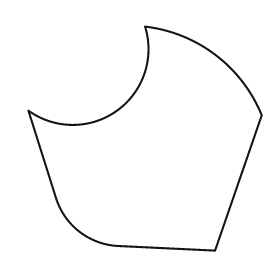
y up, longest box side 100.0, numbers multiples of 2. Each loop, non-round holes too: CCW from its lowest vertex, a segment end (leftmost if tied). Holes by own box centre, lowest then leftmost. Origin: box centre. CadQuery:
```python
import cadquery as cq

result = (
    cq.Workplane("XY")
    .moveTo(30.0, -48.0)
    .lineTo(50.0, 10.0)
    .threePointArc((30.0, 36.0), (0.0, 48.0))
    .threePointArc((-12.0, 12.0), (-50.0, 12.0))
    .lineTo(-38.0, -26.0)
    .threePointArc((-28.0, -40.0), (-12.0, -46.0))
    .close()
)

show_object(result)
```